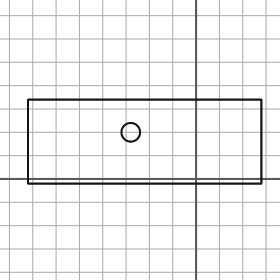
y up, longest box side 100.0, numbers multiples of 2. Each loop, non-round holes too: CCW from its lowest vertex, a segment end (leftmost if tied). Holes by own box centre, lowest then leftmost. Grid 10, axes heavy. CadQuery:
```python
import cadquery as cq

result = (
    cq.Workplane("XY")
    .moveTo(-72.0, -2.0)
    .lineTo(28.0, -2.0)
    .lineTo(28.0, 34.0)
    .lineTo(-72.0, 34.0)
    .close()
    .moveTo(-28.0, 20.0)
    .circle(4.0)
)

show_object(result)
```